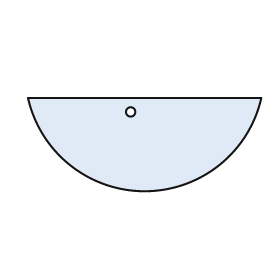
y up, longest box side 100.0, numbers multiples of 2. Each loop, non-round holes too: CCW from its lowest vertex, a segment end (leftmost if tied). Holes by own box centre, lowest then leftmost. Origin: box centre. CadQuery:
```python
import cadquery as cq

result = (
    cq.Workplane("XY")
    .moveTo(-50.0, 20.0)
    .threePointArc((0.0, -20.0), (50.0, 20.0))
    .close()
    .moveTo(-6.0, 14.0)
    .circle(2.0)
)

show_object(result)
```